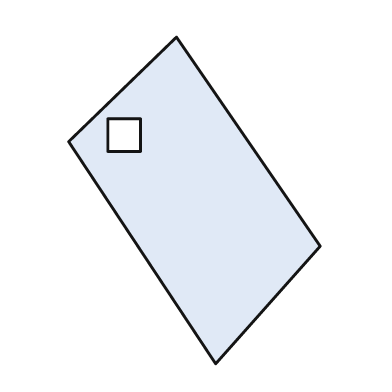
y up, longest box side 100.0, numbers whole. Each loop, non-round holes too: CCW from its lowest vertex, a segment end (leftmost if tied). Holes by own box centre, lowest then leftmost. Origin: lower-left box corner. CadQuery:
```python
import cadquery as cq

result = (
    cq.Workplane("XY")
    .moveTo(45.0, 0.0)
    .lineTo(77.0, 36.0)
    .lineTo(33.0, 100.0)
    .lineTo(0.0, 68.0)
    .close()
    .moveTo(12.0, 65.0)
    .lineTo(22.0, 65.0)
    .lineTo(22.0, 75.0)
    .lineTo(12.0, 75.0)
    .close()
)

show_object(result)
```